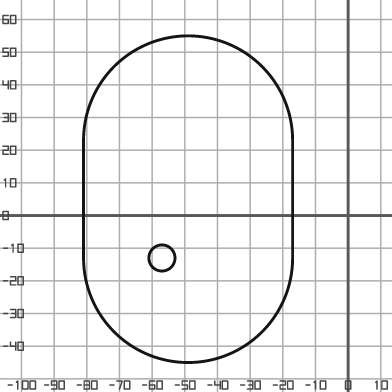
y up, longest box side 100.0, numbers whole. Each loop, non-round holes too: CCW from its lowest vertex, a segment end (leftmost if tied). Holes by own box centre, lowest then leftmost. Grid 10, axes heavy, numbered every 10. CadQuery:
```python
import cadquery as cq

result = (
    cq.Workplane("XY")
    .moveTo(-81.0, -13.0)
    .threePointArc((-49.0, -45.0), (-17.0, -13.0))
    .lineTo(-17.0, 23.0)
    .threePointArc((-49.0, 55.0), (-81.0, 23.0))
    .close()
    .moveTo(-57.0, -13.0)
    .circle(4.0)
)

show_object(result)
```